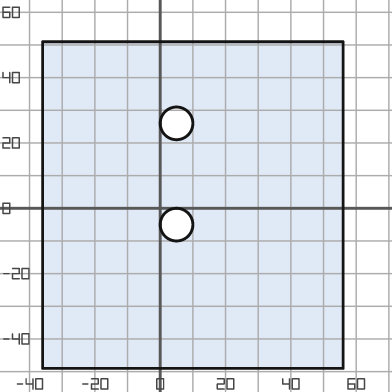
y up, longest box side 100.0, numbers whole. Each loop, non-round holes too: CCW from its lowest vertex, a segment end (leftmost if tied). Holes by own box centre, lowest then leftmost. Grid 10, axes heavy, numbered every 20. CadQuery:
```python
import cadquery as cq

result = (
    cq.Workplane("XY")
    .moveTo(-36.0, -49.0)
    .lineTo(56.0, -49.0)
    .lineTo(56.0, 51.0)
    .lineTo(-36.0, 51.0)
    .close()
    .moveTo(5.0, -5.0)
    .circle(5.0)
    .moveTo(5.0, 26.0)
    .circle(5.0)
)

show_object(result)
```